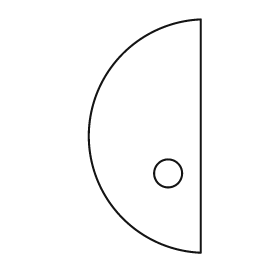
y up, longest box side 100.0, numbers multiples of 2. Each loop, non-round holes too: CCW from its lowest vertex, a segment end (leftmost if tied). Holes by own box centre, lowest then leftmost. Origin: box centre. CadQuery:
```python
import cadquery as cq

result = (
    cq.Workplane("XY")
    .moveTo(24.0, -50.0)
    .lineTo(24.0, 50.0)
    .threePointArc((-24.0, 0.0), (24.0, -50.0))
    .close()
    .moveTo(10.0, -16.0)
    .circle(6.0)
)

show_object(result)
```